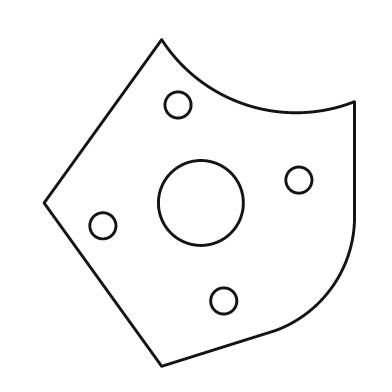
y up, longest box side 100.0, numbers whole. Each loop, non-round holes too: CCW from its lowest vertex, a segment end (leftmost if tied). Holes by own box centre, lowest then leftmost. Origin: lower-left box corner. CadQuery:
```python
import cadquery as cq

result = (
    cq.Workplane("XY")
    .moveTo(36.0, 0.0)
    .lineTo(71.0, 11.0)
    .threePointArc((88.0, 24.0), (95.0, 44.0))
    .lineTo(95.0, 81.0)
    .threePointArc((62.0, 80.0), (36.0, 100.0))
    .lineTo(0.0, 50.0)
    .close()
    .moveTo(55.0, 20.0)
    .circle(4.0)
    .moveTo(18.0, 43.0)
    .circle(4.0)
    .moveTo(48.0, 50.0)
    .circle(13.0)
    .moveTo(78.0, 57.0)
    .circle(4.0)
    .moveTo(41.0, 80.0)
    .circle(4.0)
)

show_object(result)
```